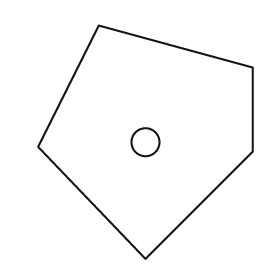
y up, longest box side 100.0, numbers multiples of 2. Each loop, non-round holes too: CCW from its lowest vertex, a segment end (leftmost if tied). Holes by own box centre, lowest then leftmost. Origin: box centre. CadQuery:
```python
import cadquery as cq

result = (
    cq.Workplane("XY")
    .moveTo(0.0, -50.0)
    .lineTo(46.0, -4.0)
    .lineTo(46.0, 32.0)
    .lineTo(-20.0, 50.0)
    .lineTo(-46.0, -2.0)
    .close()
    .moveTo(0.0, 0.0)
    .circle(6.0)
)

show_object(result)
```